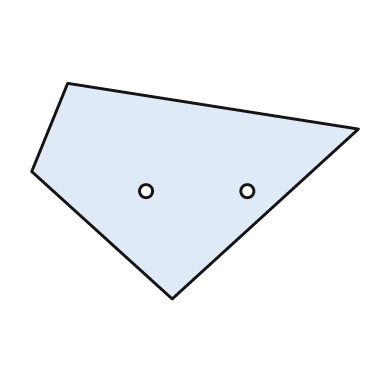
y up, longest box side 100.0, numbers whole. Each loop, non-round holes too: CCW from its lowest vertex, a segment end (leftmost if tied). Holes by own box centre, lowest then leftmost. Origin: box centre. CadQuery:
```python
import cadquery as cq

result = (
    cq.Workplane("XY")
    .moveTo(-7.0, -33.0)
    .lineTo(50.0, 19.0)
    .lineTo(-39.0, 33.0)
    .lineTo(-50.0, 6.0)
    .close()
    .moveTo(-15.0, 0.0)
    .circle(2.0)
    .moveTo(16.0, 0.0)
    .circle(2.0)
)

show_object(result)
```